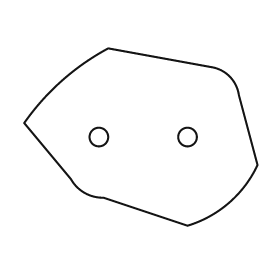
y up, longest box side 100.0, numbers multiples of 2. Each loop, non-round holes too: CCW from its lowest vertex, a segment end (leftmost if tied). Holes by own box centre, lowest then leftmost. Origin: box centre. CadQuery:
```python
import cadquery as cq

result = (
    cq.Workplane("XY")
    .moveTo(20.0, -38.0)
    .threePointArc((38.0, -28.0), (50.0, -12.0))
    .lineTo(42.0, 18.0)
    .threePointArc((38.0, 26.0), (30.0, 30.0))
    .lineTo(-14.0, 38.0)
    .threePointArc((-34.0, 24.0), (-50.0, 6.0))
    .lineTo(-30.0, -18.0)
    .threePointArc((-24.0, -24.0), (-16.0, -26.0))
    .close()
    .moveTo(-18.0, 0.0)
    .circle(4.0)
    .moveTo(20.0, 0.0)
    .circle(4.0)
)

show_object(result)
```